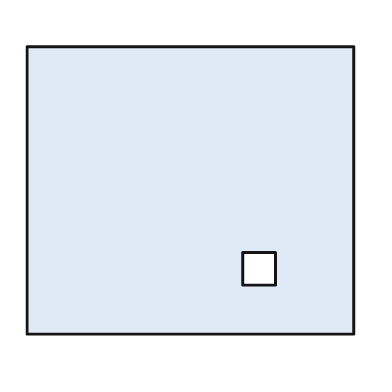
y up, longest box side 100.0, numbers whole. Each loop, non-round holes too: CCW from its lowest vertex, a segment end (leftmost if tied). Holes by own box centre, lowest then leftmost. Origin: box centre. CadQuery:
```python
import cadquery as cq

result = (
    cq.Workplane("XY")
    .moveTo(-50.0, -44.0)
    .lineTo(50.0, -44.0)
    .lineTo(50.0, 44.0)
    .lineTo(-50.0, 44.0)
    .close()
    .moveTo(16.0, -29.0)
    .lineTo(26.0, -29.0)
    .lineTo(26.0, -19.0)
    .lineTo(16.0, -19.0)
    .close()
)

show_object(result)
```